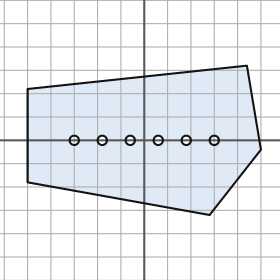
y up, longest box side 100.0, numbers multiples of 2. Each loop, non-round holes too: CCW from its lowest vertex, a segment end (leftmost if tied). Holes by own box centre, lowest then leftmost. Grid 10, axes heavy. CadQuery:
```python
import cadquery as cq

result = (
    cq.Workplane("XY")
    .moveTo(28.0, -32.0)
    .lineTo(50.0, -4.0)
    .lineTo(44.0, 32.0)
    .lineTo(-50.0, 22.0)
    .lineTo(-50.0, -18.0)
    .close()
    .moveTo(-30.0, 0.0)
    .circle(2.0)
    .moveTo(-18.0, 0.0)
    .circle(2.0)
    .moveTo(-6.0, 0.0)
    .circle(2.0)
    .moveTo(6.0, 0.0)
    .circle(2.0)
    .moveTo(18.0, 0.0)
    .circle(2.0)
    .moveTo(30.0, 0.0)
    .circle(2.0)
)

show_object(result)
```